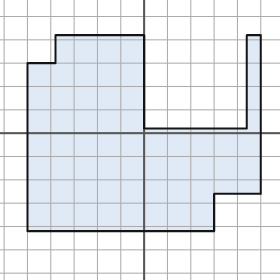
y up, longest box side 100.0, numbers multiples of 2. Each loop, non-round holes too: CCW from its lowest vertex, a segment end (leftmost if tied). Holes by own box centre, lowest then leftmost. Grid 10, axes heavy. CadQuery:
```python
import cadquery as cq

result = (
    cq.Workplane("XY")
    .moveTo(-50.0, -42.0)
    .lineTo(30.0, -42.0)
    .lineTo(30.0, -26.0)
    .lineTo(50.0, -26.0)
    .lineTo(50.0, 42.0)
    .lineTo(44.0, 42.0)
    .lineTo(44.0, 2.0)
    .lineTo(0.0, 2.0)
    .lineTo(0.0, 42.0)
    .lineTo(-38.0, 42.0)
    .lineTo(-38.0, 30.0)
    .lineTo(-50.0, 30.0)
    .close()
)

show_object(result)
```